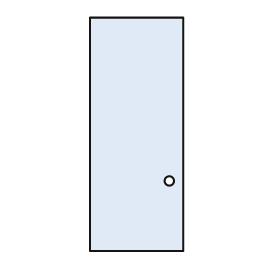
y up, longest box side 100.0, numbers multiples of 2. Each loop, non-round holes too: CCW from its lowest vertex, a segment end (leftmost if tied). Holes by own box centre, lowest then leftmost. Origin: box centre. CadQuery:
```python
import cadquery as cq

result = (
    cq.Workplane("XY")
    .moveTo(-20.0, -50.0)
    .lineTo(20.0, -50.0)
    .lineTo(20.0, 50.0)
    .lineTo(-20.0, 50.0)
    .close()
    .moveTo(14.0, -20.0)
    .circle(2.0)
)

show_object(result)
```